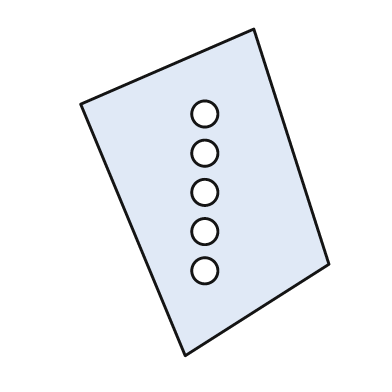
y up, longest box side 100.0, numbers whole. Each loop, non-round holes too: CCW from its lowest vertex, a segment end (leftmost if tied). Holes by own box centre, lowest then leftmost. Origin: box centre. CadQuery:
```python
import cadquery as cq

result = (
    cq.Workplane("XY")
    .moveTo(-6.0, -50.0)
    .lineTo(38.0, -22.0)
    .lineTo(15.0, 50.0)
    .lineTo(-38.0, 27.0)
    .close()
    .moveTo(0.0, -24.0)
    .circle(4.0)
    .moveTo(0.0, -12.0)
    .circle(4.0)
    .moveTo(0.0, 0.0)
    .circle(4.0)
    .moveTo(0.0, 12.0)
    .circle(4.0)
    .moveTo(0.0, 24.0)
    .circle(4.0)
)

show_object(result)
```